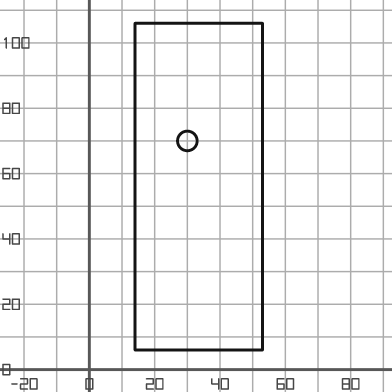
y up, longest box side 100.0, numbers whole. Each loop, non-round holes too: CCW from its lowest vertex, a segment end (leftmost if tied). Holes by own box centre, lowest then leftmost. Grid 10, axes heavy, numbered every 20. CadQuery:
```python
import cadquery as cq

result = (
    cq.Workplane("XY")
    .moveTo(14.0, 6.0)
    .lineTo(53.0, 6.0)
    .lineTo(53.0, 106.0)
    .lineTo(14.0, 106.0)
    .close()
    .moveTo(30.0, 70.0)
    .circle(3.0)
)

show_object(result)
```